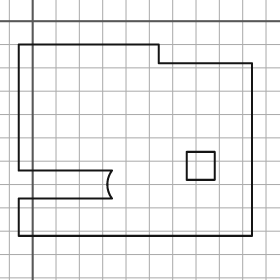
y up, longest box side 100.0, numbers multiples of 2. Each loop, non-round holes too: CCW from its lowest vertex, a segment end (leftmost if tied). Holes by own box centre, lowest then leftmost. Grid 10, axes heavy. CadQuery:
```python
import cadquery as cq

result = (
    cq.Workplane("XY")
    .moveTo(-6.0, -92.0)
    .lineTo(94.0, -92.0)
    .lineTo(94.0, -18.0)
    .lineTo(54.0, -18.0)
    .lineTo(54.0, -10.0)
    .lineTo(-6.0, -10.0)
    .lineTo(-6.0, -64.0)
    .lineTo(34.0, -64.0)
    .threePointArc((32.0, -70.0), (34.0, -76.0))
    .lineTo(-6.0, -76.0)
    .close()
    .moveTo(66.0, -68.0)
    .lineTo(78.0, -68.0)
    .lineTo(78.0, -56.0)
    .lineTo(66.0, -56.0)
    .close()
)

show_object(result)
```